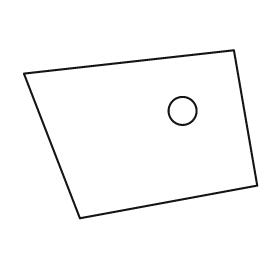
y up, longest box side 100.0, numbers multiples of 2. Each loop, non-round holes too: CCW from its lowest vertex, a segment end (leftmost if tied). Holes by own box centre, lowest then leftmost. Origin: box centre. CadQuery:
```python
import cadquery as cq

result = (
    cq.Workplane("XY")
    .moveTo(-26.0, -36.0)
    .lineTo(50.0, -22.0)
    .lineTo(40.0, 36.0)
    .lineTo(-50.0, 26.0)
    .close()
    .moveTo(18.0, 10.0)
    .circle(6.0)
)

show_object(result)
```